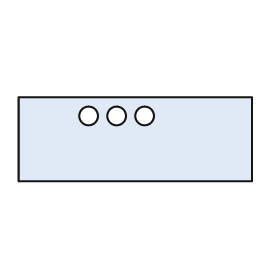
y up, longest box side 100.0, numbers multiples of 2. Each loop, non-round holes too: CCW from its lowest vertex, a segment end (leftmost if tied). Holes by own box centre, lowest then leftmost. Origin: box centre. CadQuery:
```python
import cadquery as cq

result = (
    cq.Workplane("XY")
    .moveTo(-50.0, -18.0)
    .lineTo(50.0, -18.0)
    .lineTo(50.0, 18.0)
    .lineTo(-50.0, 18.0)
    .close()
    .moveTo(-20.0, 10.0)
    .circle(4.0)
    .moveTo(-8.0, 10.0)
    .circle(4.0)
    .moveTo(4.0, 10.0)
    .circle(4.0)
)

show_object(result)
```